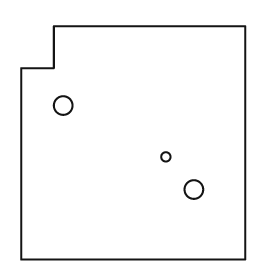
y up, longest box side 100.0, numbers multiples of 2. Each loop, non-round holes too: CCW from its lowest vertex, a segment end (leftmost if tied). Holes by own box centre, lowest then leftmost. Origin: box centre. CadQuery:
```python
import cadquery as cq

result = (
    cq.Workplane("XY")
    .moveTo(-48.0, -50.0)
    .lineTo(48.0, -50.0)
    .lineTo(48.0, 50.0)
    .lineTo(-34.0, 50.0)
    .lineTo(-34.0, 32.0)
    .lineTo(-48.0, 32.0)
    .close()
    .moveTo(26.0, -20.0)
    .circle(4.0)
    .moveTo(14.0, -6.0)
    .circle(2.0)
    .moveTo(-30.0, 16.0)
    .circle(4.0)
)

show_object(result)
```